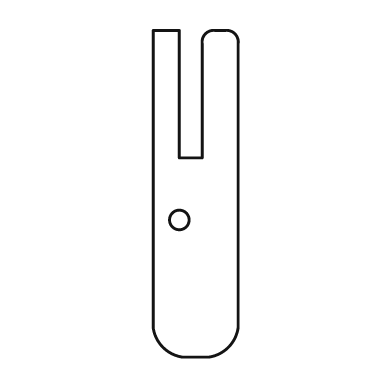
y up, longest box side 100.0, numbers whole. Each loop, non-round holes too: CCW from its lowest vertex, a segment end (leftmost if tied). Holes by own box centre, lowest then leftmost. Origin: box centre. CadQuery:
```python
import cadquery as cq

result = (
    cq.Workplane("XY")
    .moveTo(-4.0, -50.0)
    .lineTo(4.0, -50.0)
    .threePointArc((10.0, -47.0), (13.0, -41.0))
    .lineTo(13.0, 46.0)
    .threePointArc((12.0, 49.0), (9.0, 50.0))
    .lineTo(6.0, 50.0)
    .threePointArc((3.0, 49.0), (2.0, 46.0))
    .lineTo(2.0, 11.0)
    .lineTo(-5.0, 11.0)
    .lineTo(-5.0, 50.0)
    .lineTo(-13.0, 50.0)
    .lineTo(-13.0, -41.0)
    .threePointArc((-10.0, -47.0), (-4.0, -50.0))
    .close()
    .moveTo(-5.0, -8.0)
    .circle(3.0)
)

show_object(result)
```